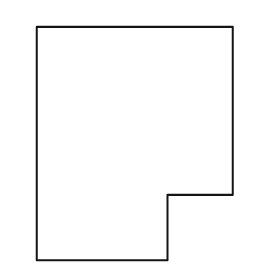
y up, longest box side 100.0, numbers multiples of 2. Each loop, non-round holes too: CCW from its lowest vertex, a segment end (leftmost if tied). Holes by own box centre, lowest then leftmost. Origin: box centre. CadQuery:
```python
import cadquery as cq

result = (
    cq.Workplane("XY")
    .moveTo(-42.0, -50.0)
    .lineTo(14.0, -50.0)
    .lineTo(14.0, -22.0)
    .lineTo(42.0, -22.0)
    .lineTo(42.0, 50.0)
    .lineTo(-42.0, 50.0)
    .close()
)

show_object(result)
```